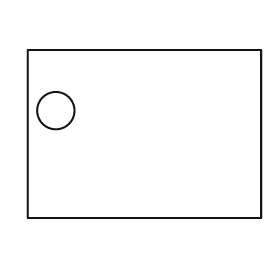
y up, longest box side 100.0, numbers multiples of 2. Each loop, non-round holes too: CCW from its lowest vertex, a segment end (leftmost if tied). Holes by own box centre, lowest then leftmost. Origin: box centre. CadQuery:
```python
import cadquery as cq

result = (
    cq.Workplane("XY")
    .moveTo(-50.0, -36.0)
    .lineTo(50.0, -36.0)
    .lineTo(50.0, 36.0)
    .lineTo(-50.0, 36.0)
    .close()
    .moveTo(-38.0, 10.0)
    .circle(8.0)
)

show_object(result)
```